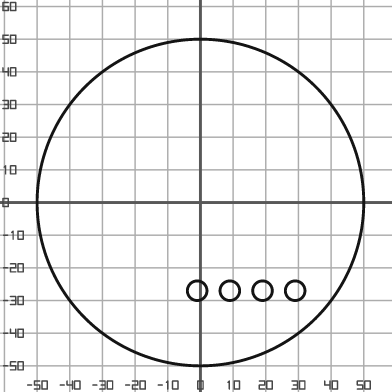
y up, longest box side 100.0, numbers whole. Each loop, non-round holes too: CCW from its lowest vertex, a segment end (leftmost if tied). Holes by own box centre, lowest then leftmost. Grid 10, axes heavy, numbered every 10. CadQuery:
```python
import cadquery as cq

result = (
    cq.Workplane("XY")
    .moveTo(0.0, 0.0)
    .circle(50.0)
    .moveTo(-1.0, -27.0)
    .circle(3.0)
    .moveTo(9.0, -27.0)
    .circle(3.0)
    .moveTo(19.0, -27.0)
    .circle(3.0)
    .moveTo(29.0, -27.0)
    .circle(3.0)
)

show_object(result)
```